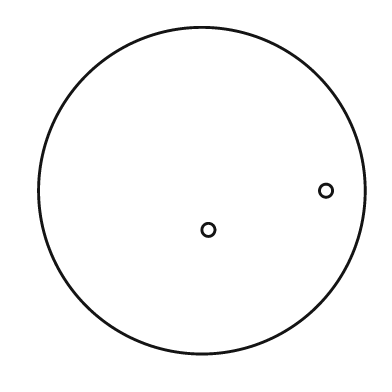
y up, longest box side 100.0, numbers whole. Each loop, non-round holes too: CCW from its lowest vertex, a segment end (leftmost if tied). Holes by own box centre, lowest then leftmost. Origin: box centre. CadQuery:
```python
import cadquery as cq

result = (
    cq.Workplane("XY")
    .moveTo(0.0, 0.0)
    .circle(50.0)
    .moveTo(2.0, -12.0)
    .circle(2.0)
    .moveTo(38.0, 0.0)
    .circle(2.0)
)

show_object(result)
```